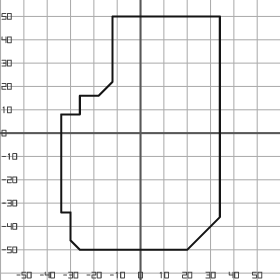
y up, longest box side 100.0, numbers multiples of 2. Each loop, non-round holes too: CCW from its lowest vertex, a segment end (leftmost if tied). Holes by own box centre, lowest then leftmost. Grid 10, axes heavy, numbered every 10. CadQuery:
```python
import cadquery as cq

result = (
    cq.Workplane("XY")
    .moveTo(-26.0, -50.0)
    .lineTo(20.0, -50.0)
    .lineTo(34.0, -36.0)
    .lineTo(34.0, 50.0)
    .lineTo(-12.0, 50.0)
    .lineTo(-12.0, 22.0)
    .lineTo(-18.0, 16.0)
    .lineTo(-26.0, 16.0)
    .lineTo(-26.0, 8.0)
    .lineTo(-34.0, 8.0)
    .lineTo(-34.0, -34.0)
    .lineTo(-30.0, -34.0)
    .lineTo(-30.0, -46.0)
    .close()
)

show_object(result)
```